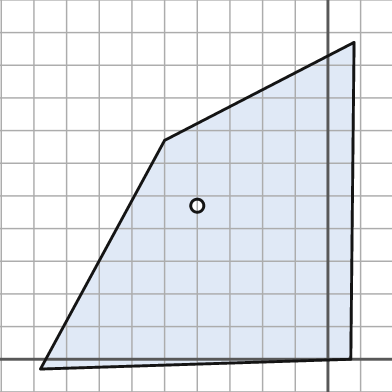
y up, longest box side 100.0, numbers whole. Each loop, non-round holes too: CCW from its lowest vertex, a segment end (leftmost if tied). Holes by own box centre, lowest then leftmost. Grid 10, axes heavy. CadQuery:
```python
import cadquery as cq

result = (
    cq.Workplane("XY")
    .moveTo(-88.0, -3.0)
    .lineTo(7.0, 0.0)
    .lineTo(8.0, 97.0)
    .lineTo(-50.0, 67.0)
    .close()
    .moveTo(-40.0, 47.0)
    .circle(2.0)
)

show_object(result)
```